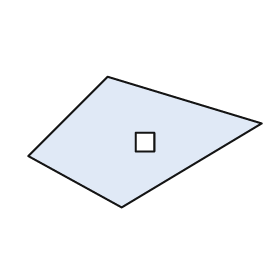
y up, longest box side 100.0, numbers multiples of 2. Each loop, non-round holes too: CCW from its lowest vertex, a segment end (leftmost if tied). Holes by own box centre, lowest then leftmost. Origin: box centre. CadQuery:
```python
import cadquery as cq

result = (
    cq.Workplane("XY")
    .moveTo(-10.0, -28.0)
    .lineTo(50.0, 8.0)
    .lineTo(-16.0, 28.0)
    .lineTo(-50.0, -6.0)
    .close()
    .moveTo(-4.0, -4.0)
    .lineTo(4.0, -4.0)
    .lineTo(4.0, 4.0)
    .lineTo(-4.0, 4.0)
    .close()
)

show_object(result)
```